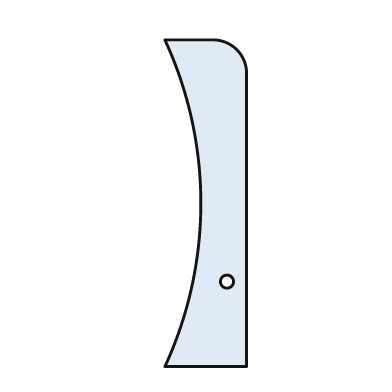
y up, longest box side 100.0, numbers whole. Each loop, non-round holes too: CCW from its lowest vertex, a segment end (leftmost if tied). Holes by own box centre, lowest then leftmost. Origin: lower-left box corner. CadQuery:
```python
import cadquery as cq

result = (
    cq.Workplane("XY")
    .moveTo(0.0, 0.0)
    .lineTo(25.0, 0.0)
    .lineTo(25.0, 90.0)
    .threePointArc((22.0, 97.0), (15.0, 100.0))
    .lineTo(0.0, 100.0)
    .threePointArc((11.0, 50.0), (0.0, 0.0))
    .close()
    .moveTo(19.0, 26.0)
    .circle(2.0)
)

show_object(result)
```